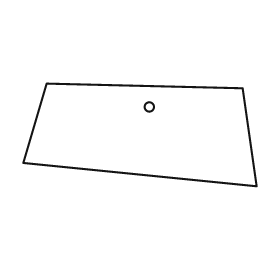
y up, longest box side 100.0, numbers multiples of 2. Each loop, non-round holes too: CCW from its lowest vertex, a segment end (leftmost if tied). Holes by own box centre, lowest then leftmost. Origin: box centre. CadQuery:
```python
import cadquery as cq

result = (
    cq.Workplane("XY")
    .moveTo(50.0, -22.0)
    .lineTo(44.0, 20.0)
    .lineTo(-40.0, 22.0)
    .lineTo(-50.0, -12.0)
    .close()
    .moveTo(4.0, 12.0)
    .circle(2.0)
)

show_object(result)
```